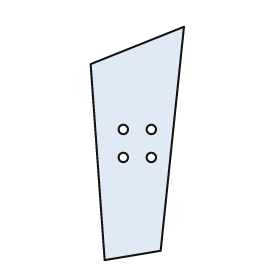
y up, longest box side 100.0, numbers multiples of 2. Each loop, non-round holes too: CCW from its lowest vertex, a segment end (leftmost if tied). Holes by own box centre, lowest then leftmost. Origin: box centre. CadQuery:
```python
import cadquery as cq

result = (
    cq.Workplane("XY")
    .moveTo(-14.0, -50.0)
    .lineTo(10.0, -46.0)
    .lineTo(20.0, 50.0)
    .lineTo(-20.0, 34.0)
    .close()
    .moveTo(-6.0, -6.0)
    .circle(2.0)
    .moveTo(6.0, -6.0)
    .circle(2.0)
    .moveTo(-6.0, 6.0)
    .circle(2.0)
    .moveTo(6.0, 6.0)
    .circle(2.0)
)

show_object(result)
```